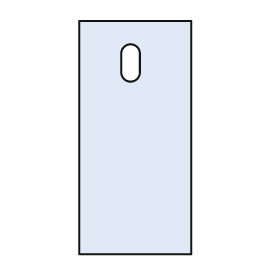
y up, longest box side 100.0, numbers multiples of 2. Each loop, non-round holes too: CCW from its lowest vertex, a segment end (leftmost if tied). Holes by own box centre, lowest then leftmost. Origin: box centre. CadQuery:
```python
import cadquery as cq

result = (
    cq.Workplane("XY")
    .moveTo(-24.0, -50.0)
    .lineTo(24.0, -50.0)
    .lineTo(24.0, 50.0)
    .lineTo(-24.0, 50.0)
    .close()
    .moveTo(-6.0, 28.0)
    .threePointArc((-2.0, 24.0), (2.0, 28.0))
    .lineTo(2.0, 36.0)
    .threePointArc((-2.0, 40.0), (-6.0, 36.0))
    .close()
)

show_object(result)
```